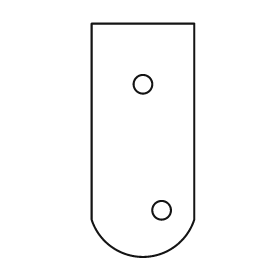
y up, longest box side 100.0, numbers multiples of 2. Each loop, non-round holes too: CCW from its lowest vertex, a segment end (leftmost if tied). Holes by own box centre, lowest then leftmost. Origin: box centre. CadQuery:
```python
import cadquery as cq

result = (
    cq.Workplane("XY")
    .moveTo(-22.0, -34.0)
    .threePointArc((0.0, -50.0), (22.0, -34.0))
    .lineTo(22.0, 50.0)
    .lineTo(-22.0, 50.0)
    .close()
    .moveTo(8.0, -30.0)
    .circle(4.0)
    .moveTo(0.0, 24.0)
    .circle(4.0)
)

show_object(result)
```